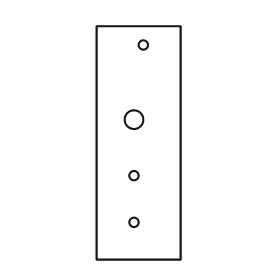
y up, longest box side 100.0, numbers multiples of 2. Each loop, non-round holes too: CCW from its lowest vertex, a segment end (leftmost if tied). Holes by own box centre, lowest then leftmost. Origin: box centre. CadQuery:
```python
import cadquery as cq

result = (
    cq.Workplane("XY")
    .moveTo(-18.0, -50.0)
    .lineTo(18.0, -50.0)
    .lineTo(18.0, 50.0)
    .lineTo(-18.0, 50.0)
    .close()
    .moveTo(-2.0, -34.0)
    .circle(2.0)
    .moveTo(-2.0, -14.0)
    .circle(2.0)
    .moveTo(-2.0, 10.0)
    .circle(4.0)
    .moveTo(2.0, 42.0)
    .circle(2.0)
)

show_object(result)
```